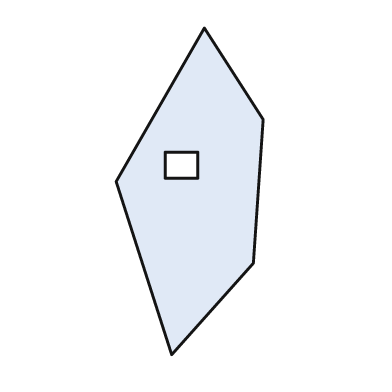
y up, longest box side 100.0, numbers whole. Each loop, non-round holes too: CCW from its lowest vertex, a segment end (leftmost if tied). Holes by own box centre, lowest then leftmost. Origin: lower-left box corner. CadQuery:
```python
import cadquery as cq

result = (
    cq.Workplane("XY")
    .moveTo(17.0, 0.0)
    .lineTo(42.0, 28.0)
    .lineTo(45.0, 72.0)
    .lineTo(27.0, 100.0)
    .lineTo(0.0, 53.0)
    .close()
    .moveTo(15.0, 54.0)
    .lineTo(25.0, 54.0)
    .lineTo(25.0, 62.0)
    .lineTo(15.0, 62.0)
    .close()
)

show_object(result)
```